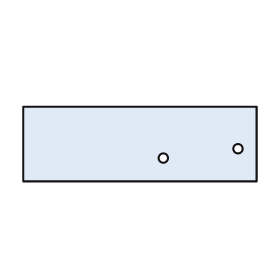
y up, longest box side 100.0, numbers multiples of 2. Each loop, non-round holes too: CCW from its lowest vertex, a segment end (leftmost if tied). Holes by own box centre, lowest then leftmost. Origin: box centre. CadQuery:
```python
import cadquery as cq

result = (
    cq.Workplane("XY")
    .moveTo(-50.0, -16.0)
    .lineTo(50.0, -16.0)
    .lineTo(50.0, 16.0)
    .lineTo(-50.0, 16.0)
    .close()
    .moveTo(10.0, -6.0)
    .circle(2.0)
    .moveTo(42.0, -2.0)
    .circle(2.0)
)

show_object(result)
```